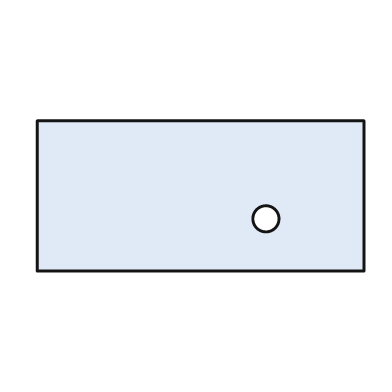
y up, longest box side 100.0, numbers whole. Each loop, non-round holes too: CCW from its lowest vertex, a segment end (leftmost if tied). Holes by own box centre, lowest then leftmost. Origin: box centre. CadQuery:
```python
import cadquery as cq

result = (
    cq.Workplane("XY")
    .moveTo(-50.0, -23.0)
    .lineTo(50.0, -23.0)
    .lineTo(50.0, 23.0)
    .lineTo(-50.0, 23.0)
    .close()
    .moveTo(20.0, -7.0)
    .circle(4.0)
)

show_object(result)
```